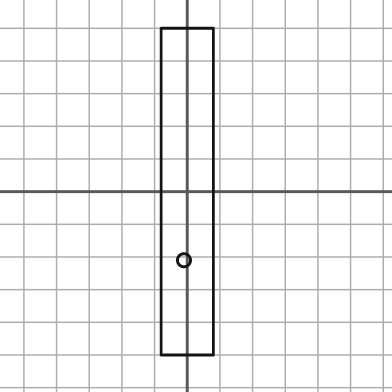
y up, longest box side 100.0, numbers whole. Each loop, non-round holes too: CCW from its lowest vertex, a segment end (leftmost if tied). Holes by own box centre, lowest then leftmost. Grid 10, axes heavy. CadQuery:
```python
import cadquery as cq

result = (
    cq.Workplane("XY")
    .moveTo(-8.0, -50.0)
    .lineTo(8.0, -50.0)
    .lineTo(8.0, 50.0)
    .lineTo(-8.0, 50.0)
    .close()
    .moveTo(-1.0, -21.0)
    .circle(2.0)
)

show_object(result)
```